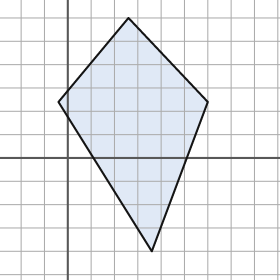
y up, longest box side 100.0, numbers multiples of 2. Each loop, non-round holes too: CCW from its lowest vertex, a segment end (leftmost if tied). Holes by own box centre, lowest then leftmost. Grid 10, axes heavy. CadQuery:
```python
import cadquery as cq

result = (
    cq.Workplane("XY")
    .moveTo(36.0, -40.0)
    .lineTo(60.0, 24.0)
    .lineTo(26.0, 60.0)
    .lineTo(-4.0, 24.0)
    .close()
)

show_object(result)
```